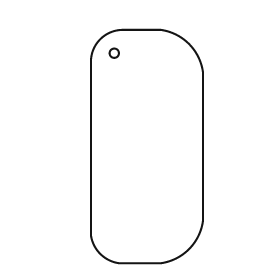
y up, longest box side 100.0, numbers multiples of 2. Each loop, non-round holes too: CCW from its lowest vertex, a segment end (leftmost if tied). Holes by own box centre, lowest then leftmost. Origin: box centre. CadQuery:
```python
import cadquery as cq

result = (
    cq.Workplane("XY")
    .moveTo(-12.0, -50.0)
    .lineTo(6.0, -50.0)
    .threePointArc((18.0, -44.0), (24.0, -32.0))
    .lineTo(24.0, 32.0)
    .threePointArc((18.0, 44.0), (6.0, 50.0))
    .lineTo(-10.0, 50.0)
    .threePointArc((-20.0, 46.0), (-24.0, 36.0))
    .lineTo(-24.0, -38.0)
    .threePointArc((-20.0, -46.0), (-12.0, -50.0))
    .close()
    .moveTo(-14.0, 40.0)
    .circle(2.0)
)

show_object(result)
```